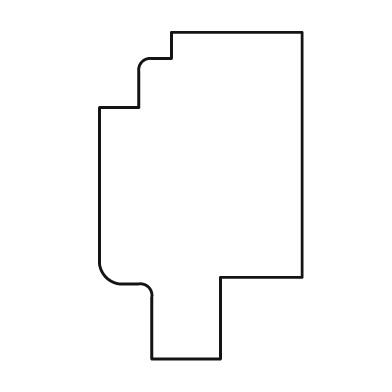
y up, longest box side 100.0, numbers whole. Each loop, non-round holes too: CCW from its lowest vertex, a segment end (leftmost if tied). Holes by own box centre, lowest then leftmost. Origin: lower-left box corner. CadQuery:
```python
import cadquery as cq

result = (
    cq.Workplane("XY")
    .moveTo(16.0, 0.0)
    .lineTo(37.0, 0.0)
    .lineTo(37.0, 25.0)
    .lineTo(62.0, 25.0)
    .lineTo(62.0, 100.0)
    .lineTo(22.0, 100.0)
    .lineTo(22.0, 92.0)
    .lineTo(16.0, 92.0)
    .threePointArc((13.0, 91.0), (12.0, 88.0))
    .lineTo(12.0, 77.0)
    .lineTo(0.0, 77.0)
    .lineTo(0.0, 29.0)
    .threePointArc((2.0, 25.0), (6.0, 23.0))
    .lineTo(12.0, 23.0)
    .threePointArc((15.0, 22.0), (16.0, 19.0))
    .close()
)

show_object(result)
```